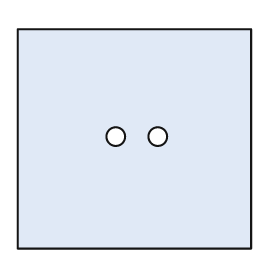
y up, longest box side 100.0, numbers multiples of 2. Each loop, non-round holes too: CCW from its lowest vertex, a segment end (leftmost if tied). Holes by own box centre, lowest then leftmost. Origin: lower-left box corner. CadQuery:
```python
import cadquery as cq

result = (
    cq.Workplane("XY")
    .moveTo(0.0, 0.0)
    .lineTo(100.0, 0.0)
    .lineTo(100.0, 94.0)
    .lineTo(0.0, 94.0)
    .close()
    .moveTo(42.0, 48.0)
    .circle(4.0)
    .moveTo(60.0, 48.0)
    .circle(4.0)
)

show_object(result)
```